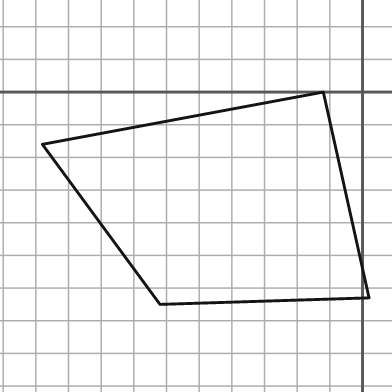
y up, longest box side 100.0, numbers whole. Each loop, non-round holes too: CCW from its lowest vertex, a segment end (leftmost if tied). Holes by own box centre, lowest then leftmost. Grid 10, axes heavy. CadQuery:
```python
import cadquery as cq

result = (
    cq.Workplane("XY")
    .moveTo(-62.0, -65.0)
    .lineTo(2.0, -63.0)
    .lineTo(-12.0, 0.0)
    .lineTo(-98.0, -16.0)
    .close()
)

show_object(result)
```